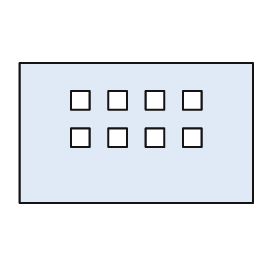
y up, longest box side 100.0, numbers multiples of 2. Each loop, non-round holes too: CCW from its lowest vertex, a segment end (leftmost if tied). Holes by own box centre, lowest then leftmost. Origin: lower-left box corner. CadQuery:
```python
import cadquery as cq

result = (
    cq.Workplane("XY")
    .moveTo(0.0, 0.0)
    .lineTo(100.0, 0.0)
    .lineTo(100.0, 60.0)
    .lineTo(0.0, 60.0)
    .close()
    .moveTo(22.0, 24.0)
    .lineTo(30.0, 24.0)
    .lineTo(30.0, 32.0)
    .lineTo(22.0, 32.0)
    .close()
    .moveTo(38.0, 24.0)
    .lineTo(46.0, 24.0)
    .lineTo(46.0, 32.0)
    .lineTo(38.0, 32.0)
    .close()
    .moveTo(54.0, 24.0)
    .lineTo(62.0, 24.0)
    .lineTo(62.0, 32.0)
    .lineTo(54.0, 32.0)
    .close()
    .moveTo(70.0, 24.0)
    .lineTo(78.0, 24.0)
    .lineTo(78.0, 32.0)
    .lineTo(70.0, 32.0)
    .close()
    .moveTo(22.0, 40.0)
    .lineTo(30.0, 40.0)
    .lineTo(30.0, 48.0)
    .lineTo(22.0, 48.0)
    .close()
    .moveTo(38.0, 40.0)
    .lineTo(46.0, 40.0)
    .lineTo(46.0, 48.0)
    .lineTo(38.0, 48.0)
    .close()
    .moveTo(54.0, 40.0)
    .lineTo(62.0, 40.0)
    .lineTo(62.0, 48.0)
    .lineTo(54.0, 48.0)
    .close()
    .moveTo(70.0, 40.0)
    .lineTo(78.0, 40.0)
    .lineTo(78.0, 48.0)
    .lineTo(70.0, 48.0)
    .close()
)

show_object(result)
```